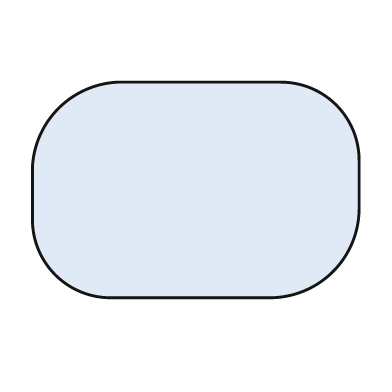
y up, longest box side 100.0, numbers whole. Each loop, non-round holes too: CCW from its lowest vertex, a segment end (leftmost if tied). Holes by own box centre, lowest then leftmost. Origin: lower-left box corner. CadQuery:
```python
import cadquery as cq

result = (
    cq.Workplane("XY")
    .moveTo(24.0, 0.0)
    .lineTo(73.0, 0.0)
    .threePointArc((92.0, 8.0), (100.0, 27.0))
    .lineTo(100.0, 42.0)
    .threePointArc((93.0, 59.0), (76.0, 66.0))
    .lineTo(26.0, 66.0)
    .threePointArc((8.0, 58.0), (0.0, 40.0))
    .lineTo(0.0, 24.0)
    .threePointArc((7.0, 7.0), (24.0, 0.0))
    .close()
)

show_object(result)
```